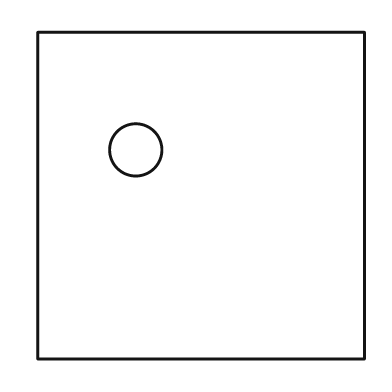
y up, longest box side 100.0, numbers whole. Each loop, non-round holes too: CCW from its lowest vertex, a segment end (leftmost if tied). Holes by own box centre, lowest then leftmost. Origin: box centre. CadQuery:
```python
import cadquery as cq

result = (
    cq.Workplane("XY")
    .moveTo(-50.0, -50.0)
    .lineTo(50.0, -50.0)
    .lineTo(50.0, 50.0)
    .lineTo(-50.0, 50.0)
    .close()
    .moveTo(-20.0, 14.0)
    .circle(8.0)
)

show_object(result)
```